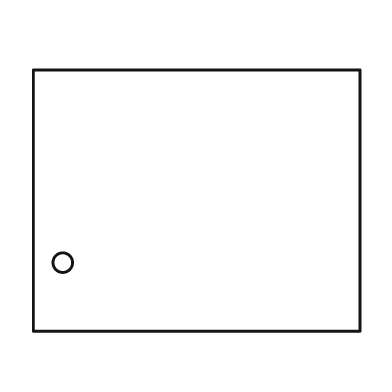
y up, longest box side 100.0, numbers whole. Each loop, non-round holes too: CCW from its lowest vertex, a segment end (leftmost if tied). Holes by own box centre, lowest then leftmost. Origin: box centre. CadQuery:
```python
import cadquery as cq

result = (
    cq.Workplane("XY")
    .moveTo(-50.0, -40.0)
    .lineTo(50.0, -40.0)
    .lineTo(50.0, 40.0)
    .lineTo(-50.0, 40.0)
    .close()
    .moveTo(-41.0, -19.0)
    .circle(3.0)
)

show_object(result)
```